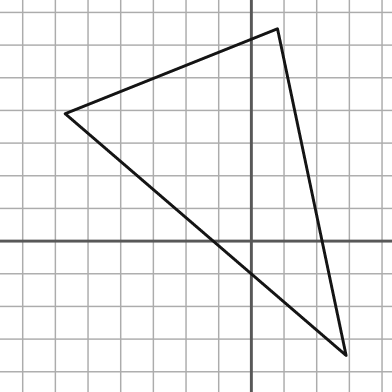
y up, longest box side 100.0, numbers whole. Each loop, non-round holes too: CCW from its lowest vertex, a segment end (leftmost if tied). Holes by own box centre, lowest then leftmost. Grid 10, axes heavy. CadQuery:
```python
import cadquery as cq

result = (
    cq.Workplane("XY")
    .moveTo(29.0, -35.0)
    .lineTo(8.0, 65.0)
    .lineTo(-57.0, 39.0)
    .close()
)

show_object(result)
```